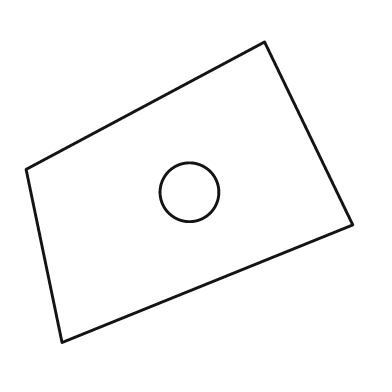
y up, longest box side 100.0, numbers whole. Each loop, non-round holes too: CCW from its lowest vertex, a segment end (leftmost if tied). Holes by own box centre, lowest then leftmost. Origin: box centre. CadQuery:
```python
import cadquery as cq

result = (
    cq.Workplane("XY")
    .moveTo(-39.0, -46.0)
    .lineTo(50.0, -10.0)
    .lineTo(23.0, 46.0)
    .lineTo(-50.0, 7.0)
    .close()
    .moveTo(0.0, 0.0)
    .circle(9.0)
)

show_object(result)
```